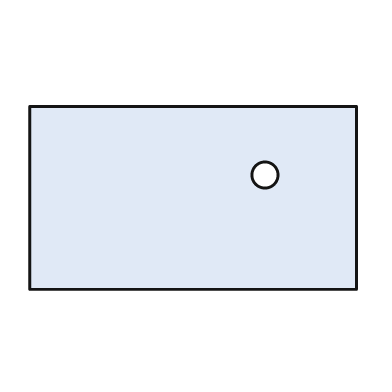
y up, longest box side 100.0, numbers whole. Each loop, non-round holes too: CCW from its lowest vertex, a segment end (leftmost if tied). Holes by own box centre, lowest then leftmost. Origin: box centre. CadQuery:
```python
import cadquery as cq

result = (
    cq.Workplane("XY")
    .moveTo(-50.0, -28.0)
    .lineTo(50.0, -28.0)
    .lineTo(50.0, 28.0)
    .lineTo(-50.0, 28.0)
    .close()
    .moveTo(22.0, 7.0)
    .circle(4.0)
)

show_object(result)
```